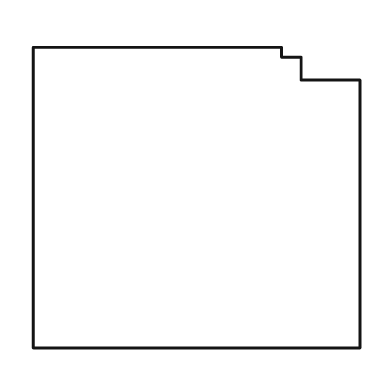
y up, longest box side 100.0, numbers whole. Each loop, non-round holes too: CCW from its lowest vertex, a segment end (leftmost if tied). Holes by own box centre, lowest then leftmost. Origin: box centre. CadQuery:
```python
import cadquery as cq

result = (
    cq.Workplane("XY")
    .moveTo(-50.0, -46.0)
    .lineTo(50.0, -46.0)
    .lineTo(50.0, 36.0)
    .lineTo(32.0, 36.0)
    .lineTo(32.0, 43.0)
    .lineTo(26.0, 43.0)
    .lineTo(26.0, 46.0)
    .lineTo(-50.0, 46.0)
    .close()
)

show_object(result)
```